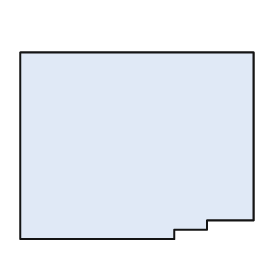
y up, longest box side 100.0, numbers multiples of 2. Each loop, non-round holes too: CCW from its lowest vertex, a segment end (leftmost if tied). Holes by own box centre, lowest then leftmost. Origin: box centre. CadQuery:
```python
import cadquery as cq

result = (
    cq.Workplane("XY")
    .moveTo(-50.0, -40.0)
    .lineTo(16.0, -40.0)
    .lineTo(16.0, -36.0)
    .lineTo(30.0, -36.0)
    .lineTo(30.0, -32.0)
    .lineTo(50.0, -32.0)
    .lineTo(50.0, 40.0)
    .lineTo(-50.0, 40.0)
    .close()
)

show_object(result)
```